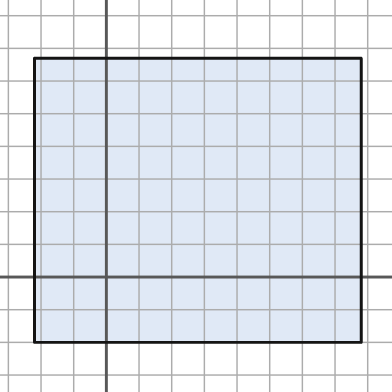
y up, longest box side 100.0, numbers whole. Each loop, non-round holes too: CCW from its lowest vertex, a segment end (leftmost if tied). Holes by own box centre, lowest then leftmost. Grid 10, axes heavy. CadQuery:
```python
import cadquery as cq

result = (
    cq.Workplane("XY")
    .moveTo(-22.0, -20.0)
    .lineTo(78.0, -20.0)
    .lineTo(78.0, 67.0)
    .lineTo(-22.0, 67.0)
    .close()
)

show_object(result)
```